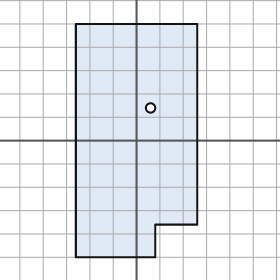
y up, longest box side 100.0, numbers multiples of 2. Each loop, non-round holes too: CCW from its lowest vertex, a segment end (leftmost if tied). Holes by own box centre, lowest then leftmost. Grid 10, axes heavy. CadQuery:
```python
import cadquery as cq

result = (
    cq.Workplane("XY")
    .moveTo(-26.0, -50.0)
    .lineTo(8.0, -50.0)
    .lineTo(8.0, -36.0)
    .lineTo(26.0, -36.0)
    .lineTo(26.0, 50.0)
    .lineTo(-26.0, 50.0)
    .close()
    .moveTo(6.0, 14.0)
    .circle(2.0)
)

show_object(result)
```